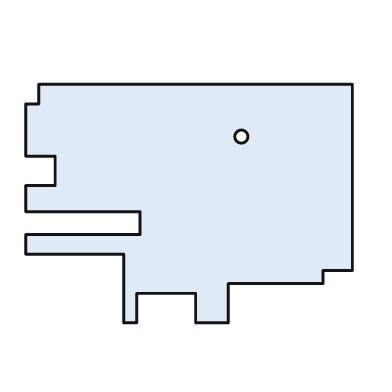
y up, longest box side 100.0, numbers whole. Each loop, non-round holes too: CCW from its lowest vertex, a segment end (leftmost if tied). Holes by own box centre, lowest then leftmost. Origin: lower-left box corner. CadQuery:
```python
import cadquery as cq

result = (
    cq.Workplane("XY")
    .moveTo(30.0, 0.0)
    .lineTo(34.0, 0.0)
    .lineTo(34.0, 9.0)
    .lineTo(52.0, 9.0)
    .lineTo(52.0, 0.0)
    .lineTo(62.0, 0.0)
    .lineTo(62.0, 12.0)
    .lineTo(91.0, 12.0)
    .lineTo(91.0, 16.0)
    .lineTo(100.0, 16.0)
    .lineTo(100.0, 73.0)
    .lineTo(4.0, 73.0)
    .lineTo(4.0, 67.0)
    .lineTo(0.0, 67.0)
    .lineTo(0.0, 51.0)
    .lineTo(9.0, 51.0)
    .lineTo(9.0, 42.0)
    .lineTo(0.0, 42.0)
    .lineTo(0.0, 34.0)
    .lineTo(35.0, 34.0)
    .lineTo(35.0, 27.0)
    .lineTo(0.0, 27.0)
    .lineTo(0.0, 21.0)
    .lineTo(30.0, 21.0)
    .close()
    .moveTo(66.0, 57.0)
    .circle(2.0)
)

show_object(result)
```